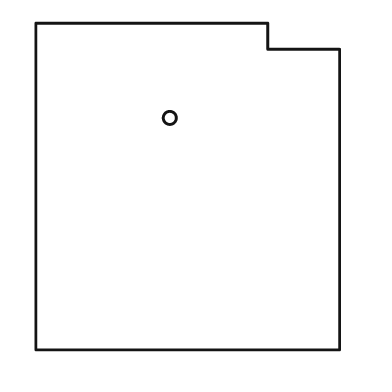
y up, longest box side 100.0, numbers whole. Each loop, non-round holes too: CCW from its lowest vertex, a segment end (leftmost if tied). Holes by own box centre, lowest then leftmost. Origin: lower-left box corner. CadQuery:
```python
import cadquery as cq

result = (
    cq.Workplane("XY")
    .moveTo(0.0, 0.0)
    .lineTo(93.0, 0.0)
    .lineTo(93.0, 92.0)
    .lineTo(71.0, 92.0)
    .lineTo(71.0, 100.0)
    .lineTo(0.0, 100.0)
    .close()
    .moveTo(41.0, 71.0)
    .circle(2.0)
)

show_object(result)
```